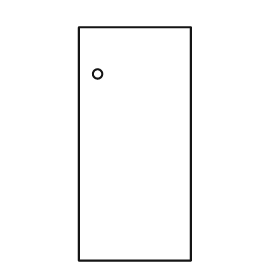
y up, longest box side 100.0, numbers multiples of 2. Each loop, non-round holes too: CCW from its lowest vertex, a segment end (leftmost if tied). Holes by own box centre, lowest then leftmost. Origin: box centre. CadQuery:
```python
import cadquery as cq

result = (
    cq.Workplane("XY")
    .moveTo(-24.0, -50.0)
    .lineTo(24.0, -50.0)
    .lineTo(24.0, 50.0)
    .lineTo(-24.0, 50.0)
    .close()
    .moveTo(-16.0, 30.0)
    .circle(2.0)
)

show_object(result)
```